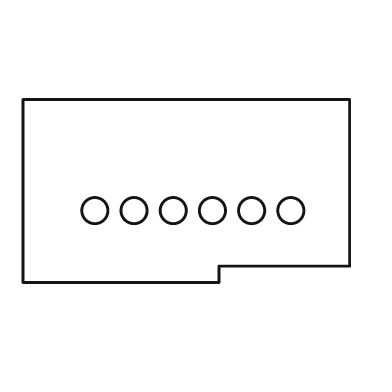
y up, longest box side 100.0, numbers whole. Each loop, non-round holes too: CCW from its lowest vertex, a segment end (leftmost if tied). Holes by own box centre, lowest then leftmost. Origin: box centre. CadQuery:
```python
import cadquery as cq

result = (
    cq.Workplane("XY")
    .moveTo(-50.0, -28.0)
    .lineTo(10.0, -28.0)
    .lineTo(10.0, -23.0)
    .lineTo(50.0, -23.0)
    .lineTo(50.0, 28.0)
    .lineTo(-50.0, 28.0)
    .close()
    .moveTo(-28.0, -6.0)
    .circle(4.0)
    .moveTo(-16.0, -6.0)
    .circle(4.0)
    .moveTo(-4.0, -6.0)
    .circle(4.0)
    .moveTo(8.0, -6.0)
    .circle(4.0)
    .moveTo(20.0, -6.0)
    .circle(4.0)
    .moveTo(32.0, -6.0)
    .circle(4.0)
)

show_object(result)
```